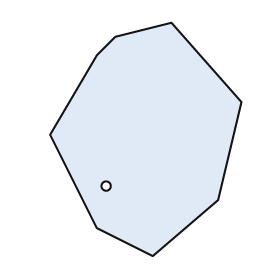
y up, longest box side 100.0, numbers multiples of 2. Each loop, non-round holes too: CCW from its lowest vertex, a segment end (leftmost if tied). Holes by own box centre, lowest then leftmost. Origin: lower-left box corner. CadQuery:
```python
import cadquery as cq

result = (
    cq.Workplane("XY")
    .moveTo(44.0, 0.0)
    .lineTo(72.0, 24.0)
    .lineTo(82.0, 66.0)
    .lineTo(52.0, 100.0)
    .lineTo(28.0, 94.0)
    .lineTo(20.0, 86.0)
    .lineTo(0.0, 52.0)
    .lineTo(20.0, 12.0)
    .close()
    .moveTo(24.0, 30.0)
    .circle(2.0)
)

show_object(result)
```